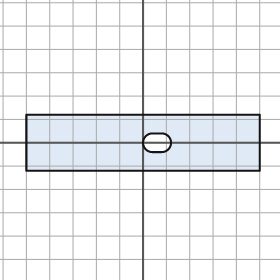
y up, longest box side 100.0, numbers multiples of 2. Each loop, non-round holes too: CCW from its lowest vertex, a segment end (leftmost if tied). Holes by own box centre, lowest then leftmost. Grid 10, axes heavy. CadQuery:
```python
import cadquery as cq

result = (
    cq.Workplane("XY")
    .moveTo(-50.0, -12.0)
    .lineTo(50.0, -12.0)
    .lineTo(50.0, 12.0)
    .lineTo(-50.0, 12.0)
    .close()
    .moveTo(4.0, -4.0)
    .lineTo(8.0, -4.0)
    .threePointArc((12.0, 0.0), (8.0, 4.0))
    .lineTo(4.0, 4.0)
    .threePointArc((0.0, 0.0), (4.0, -4.0))
    .close()
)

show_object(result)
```